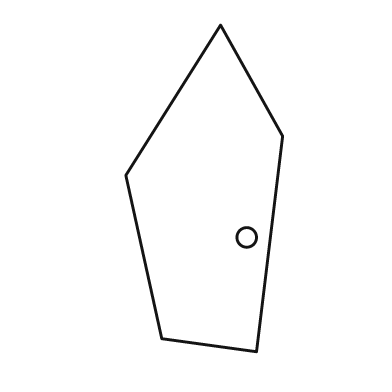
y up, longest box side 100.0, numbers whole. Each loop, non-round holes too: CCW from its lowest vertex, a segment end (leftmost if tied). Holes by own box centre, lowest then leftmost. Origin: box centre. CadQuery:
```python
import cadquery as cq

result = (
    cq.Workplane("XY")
    .moveTo(16.0, -50.0)
    .lineTo(24.0, 16.0)
    .lineTo(5.0, 50.0)
    .lineTo(-24.0, 4.0)
    .lineTo(-13.0, -46.0)
    .close()
    .moveTo(13.0, -15.0)
    .circle(3.0)
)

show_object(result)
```